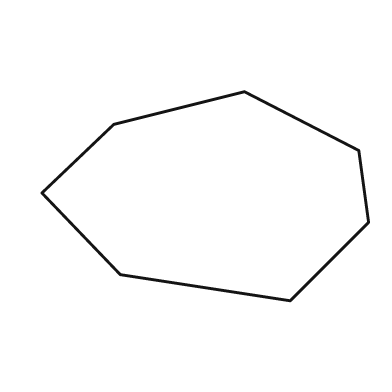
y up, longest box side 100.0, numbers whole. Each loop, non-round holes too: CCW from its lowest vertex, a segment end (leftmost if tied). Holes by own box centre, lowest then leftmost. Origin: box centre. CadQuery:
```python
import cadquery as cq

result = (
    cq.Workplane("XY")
    .moveTo(26.0, -32.0)
    .lineTo(50.0, -8.0)
    .lineTo(47.0, 14.0)
    .lineTo(12.0, 32.0)
    .lineTo(-28.0, 22.0)
    .lineTo(-50.0, 1.0)
    .lineTo(-26.0, -24.0)
    .close()
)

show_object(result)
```